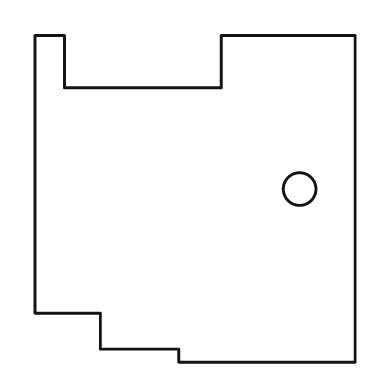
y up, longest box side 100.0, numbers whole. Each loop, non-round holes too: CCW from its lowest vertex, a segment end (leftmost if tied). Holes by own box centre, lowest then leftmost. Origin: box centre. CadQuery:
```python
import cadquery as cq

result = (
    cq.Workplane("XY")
    .moveTo(-5.0, -50.0)
    .lineTo(49.0, -50.0)
    .lineTo(49.0, 50.0)
    .lineTo(8.0, 50.0)
    .lineTo(8.0, 34.0)
    .lineTo(-40.0, 34.0)
    .lineTo(-40.0, 50.0)
    .lineTo(-49.0, 50.0)
    .lineTo(-49.0, -35.0)
    .lineTo(-29.0, -35.0)
    .lineTo(-29.0, -46.0)
    .lineTo(-5.0, -46.0)
    .close()
    .moveTo(32.0, 3.0)
    .circle(5.0)
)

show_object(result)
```